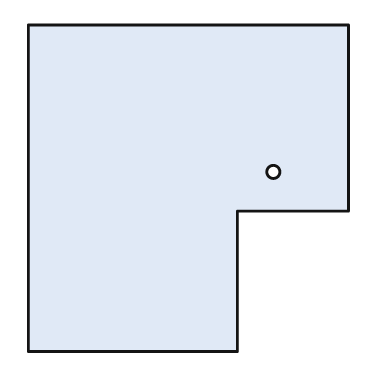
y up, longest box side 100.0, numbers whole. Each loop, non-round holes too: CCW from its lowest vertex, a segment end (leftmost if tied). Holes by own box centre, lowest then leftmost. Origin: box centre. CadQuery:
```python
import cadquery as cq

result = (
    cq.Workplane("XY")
    .moveTo(-49.0, -50.0)
    .lineTo(15.0, -50.0)
    .lineTo(15.0, -7.0)
    .lineTo(49.0, -7.0)
    .lineTo(49.0, 50.0)
    .lineTo(-49.0, 50.0)
    .close()
    .moveTo(26.0, 5.0)
    .circle(2.0)
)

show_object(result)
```